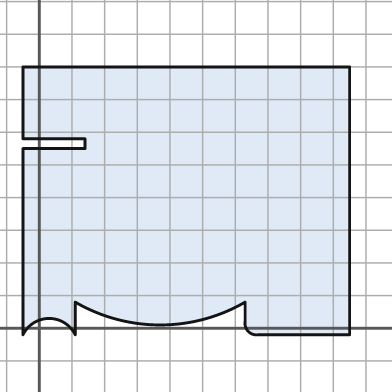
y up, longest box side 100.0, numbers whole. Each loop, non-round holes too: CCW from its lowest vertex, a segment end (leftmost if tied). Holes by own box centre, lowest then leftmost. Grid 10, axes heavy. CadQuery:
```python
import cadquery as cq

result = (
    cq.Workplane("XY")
    .moveTo(-5.0, -2.0)
    .threePointArc((3.0, 3.0), (11.0, -2.0))
    .lineTo(11.0, 8.0)
    .threePointArc((37.0, 1.0), (63.0, 8.0))
    .lineTo(63.0, 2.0)
    .threePointArc((64.0, -1.0), (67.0, -2.0))
    .lineTo(95.0, -2.0)
    .lineTo(95.0, 80.0)
    .lineTo(-5.0, 80.0)
    .lineTo(-5.0, 58.0)
    .lineTo(14.0, 58.0)
    .lineTo(14.0, 55.0)
    .lineTo(-5.0, 55.0)
    .close()
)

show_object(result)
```